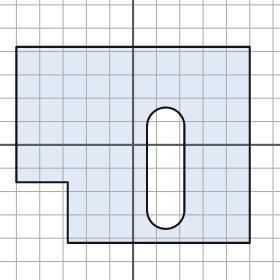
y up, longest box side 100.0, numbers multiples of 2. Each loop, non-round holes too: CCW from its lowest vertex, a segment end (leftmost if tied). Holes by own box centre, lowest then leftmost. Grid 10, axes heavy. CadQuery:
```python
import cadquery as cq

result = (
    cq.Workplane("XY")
    .moveTo(-28.0, -42.0)
    .lineTo(50.0, -42.0)
    .lineTo(50.0, 42.0)
    .lineTo(-50.0, 42.0)
    .lineTo(-50.0, -16.0)
    .lineTo(-28.0, -16.0)
    .close()
    .moveTo(6.0, -28.0)
    .threePointArc((14.0, -36.0), (22.0, -28.0))
    .lineTo(22.0, 8.0)
    .threePointArc((14.0, 16.0), (6.0, 8.0))
    .close()
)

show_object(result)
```